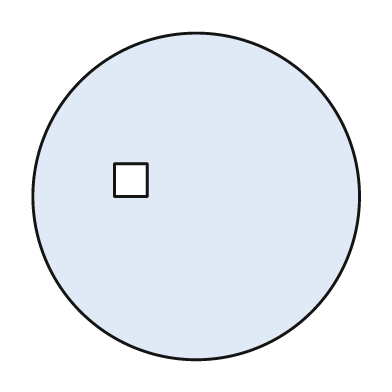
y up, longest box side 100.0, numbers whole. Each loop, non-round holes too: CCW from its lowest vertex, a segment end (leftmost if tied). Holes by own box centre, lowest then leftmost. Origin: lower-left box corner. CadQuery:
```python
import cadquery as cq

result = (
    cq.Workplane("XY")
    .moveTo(50.0, 50.0)
    .circle(50.0)
    .moveTo(25.0, 50.0)
    .lineTo(35.0, 50.0)
    .lineTo(35.0, 60.0)
    .lineTo(25.0, 60.0)
    .close()
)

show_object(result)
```